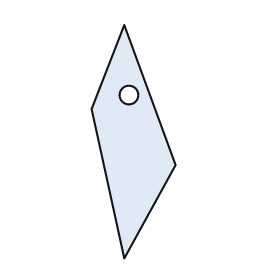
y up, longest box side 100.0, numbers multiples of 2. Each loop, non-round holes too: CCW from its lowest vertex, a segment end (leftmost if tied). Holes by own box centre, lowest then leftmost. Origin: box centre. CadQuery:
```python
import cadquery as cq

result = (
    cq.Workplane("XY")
    .moveTo(-4.0, -50.0)
    .lineTo(18.0, -10.0)
    .lineTo(-4.0, 50.0)
    .lineTo(-18.0, 14.0)
    .close()
    .moveTo(-2.0, 20.0)
    .circle(4.0)
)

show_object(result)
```